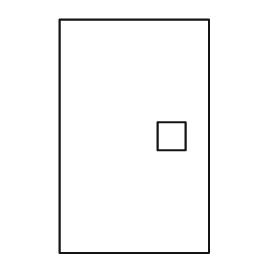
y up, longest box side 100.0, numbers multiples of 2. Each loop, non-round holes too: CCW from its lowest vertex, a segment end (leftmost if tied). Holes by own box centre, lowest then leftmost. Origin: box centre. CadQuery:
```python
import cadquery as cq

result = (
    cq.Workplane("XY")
    .moveTo(-32.0, -50.0)
    .lineTo(32.0, -50.0)
    .lineTo(32.0, 50.0)
    .lineTo(-32.0, 50.0)
    .close()
    .moveTo(10.0, -6.0)
    .lineTo(22.0, -6.0)
    .lineTo(22.0, 6.0)
    .lineTo(10.0, 6.0)
    .close()
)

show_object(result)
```